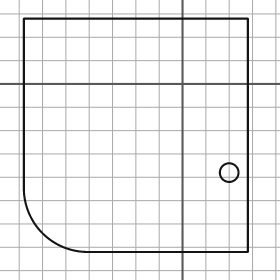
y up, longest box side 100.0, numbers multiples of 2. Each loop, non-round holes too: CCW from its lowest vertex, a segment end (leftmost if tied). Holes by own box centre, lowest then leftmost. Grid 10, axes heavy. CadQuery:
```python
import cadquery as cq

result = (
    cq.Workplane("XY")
    .moveTo(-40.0, -72.0)
    .lineTo(28.0, -72.0)
    .lineTo(28.0, 28.0)
    .lineTo(-68.0, 28.0)
    .lineTo(-68.0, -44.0)
    .threePointArc((-60.0, -64.0), (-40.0, -72.0))
    .close()
    .moveTo(20.0, -38.0)
    .circle(4.0)
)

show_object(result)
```